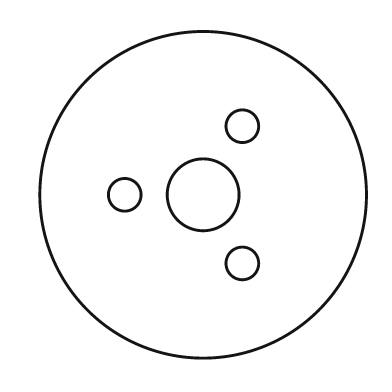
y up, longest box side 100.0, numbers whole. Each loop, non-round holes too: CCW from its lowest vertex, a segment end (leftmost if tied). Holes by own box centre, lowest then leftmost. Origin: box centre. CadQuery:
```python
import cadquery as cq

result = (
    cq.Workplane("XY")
    .moveTo(0.0, 0.0)
    .circle(50.0)
    .moveTo(12.0, -21.0)
    .circle(5.0)
    .moveTo(-24.0, 0.0)
    .circle(5.0)
    .moveTo(0.0, 0.0)
    .circle(11.0)
    .moveTo(12.0, 21.0)
    .circle(5.0)
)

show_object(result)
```